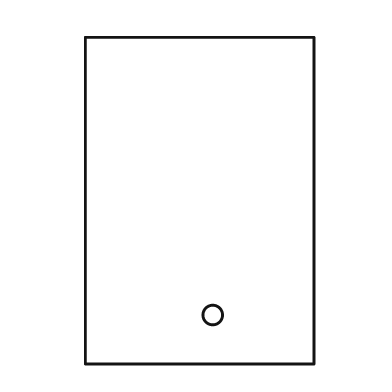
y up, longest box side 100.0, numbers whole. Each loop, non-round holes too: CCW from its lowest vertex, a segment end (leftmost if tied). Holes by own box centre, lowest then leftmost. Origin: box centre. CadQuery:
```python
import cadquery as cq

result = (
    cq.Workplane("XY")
    .moveTo(-35.0, -50.0)
    .lineTo(35.0, -50.0)
    .lineTo(35.0, 50.0)
    .lineTo(-35.0, 50.0)
    .close()
    .moveTo(4.0, -35.0)
    .circle(3.0)
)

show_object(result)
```